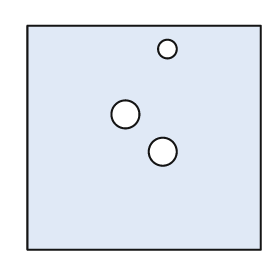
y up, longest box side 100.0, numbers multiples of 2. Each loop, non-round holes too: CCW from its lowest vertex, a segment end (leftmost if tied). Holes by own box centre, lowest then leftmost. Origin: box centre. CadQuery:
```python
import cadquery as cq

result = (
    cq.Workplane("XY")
    .moveTo(-50.0, -48.0)
    .lineTo(50.0, -48.0)
    .lineTo(50.0, 48.0)
    .lineTo(-50.0, 48.0)
    .close()
    .moveTo(8.0, -6.0)
    .circle(6.0)
    .moveTo(-8.0, 10.0)
    .circle(6.0)
    .moveTo(10.0, 38.0)
    .circle(4.0)
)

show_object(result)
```